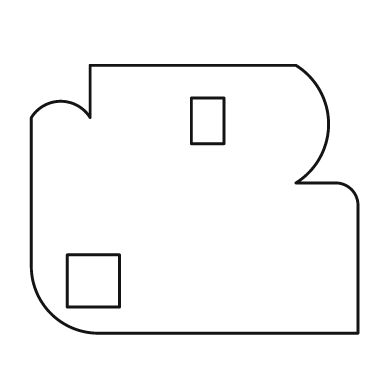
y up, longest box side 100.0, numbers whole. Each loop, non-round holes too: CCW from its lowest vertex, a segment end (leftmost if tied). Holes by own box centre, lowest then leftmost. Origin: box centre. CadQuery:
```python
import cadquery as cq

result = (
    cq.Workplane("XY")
    .moveTo(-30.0, -41.0)
    .lineTo(50.0, -41.0)
    .lineTo(50.0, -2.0)
    .threePointArc((48.0, 3.0), (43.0, 5.0))
    .lineTo(31.0, 5.0)
    .threePointArc((41.0, 23.0), (31.0, 41.0))
    .lineTo(-32.0, 41.0)
    .lineTo(-32.0, 25.0)
    .threePointArc((-41.0, 30.0), (-50.0, 25.0))
    .lineTo(-50.0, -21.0)
    .threePointArc((-44.0, -35.0), (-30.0, -41.0))
    .close()
    .moveTo(-39.0, -33.0)
    .lineTo(-23.0, -33.0)
    .lineTo(-23.0, -17.0)
    .lineTo(-39.0, -17.0)
    .close()
    .moveTo(-1.0, 17.0)
    .lineTo(9.0, 17.0)
    .lineTo(9.0, 31.0)
    .lineTo(-1.0, 31.0)
    .close()
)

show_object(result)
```